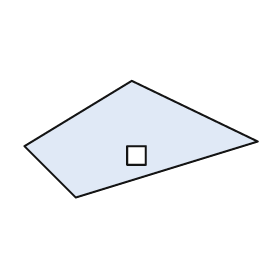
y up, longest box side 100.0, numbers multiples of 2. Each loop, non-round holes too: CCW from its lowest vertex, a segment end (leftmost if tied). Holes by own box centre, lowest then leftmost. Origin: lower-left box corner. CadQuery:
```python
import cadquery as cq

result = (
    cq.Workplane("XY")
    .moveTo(22.0, 0.0)
    .lineTo(100.0, 24.0)
    .lineTo(46.0, 50.0)
    .lineTo(0.0, 22.0)
    .close()
    .moveTo(44.0, 14.0)
    .lineTo(52.0, 14.0)
    .lineTo(52.0, 22.0)
    .lineTo(44.0, 22.0)
    .close()
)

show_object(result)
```